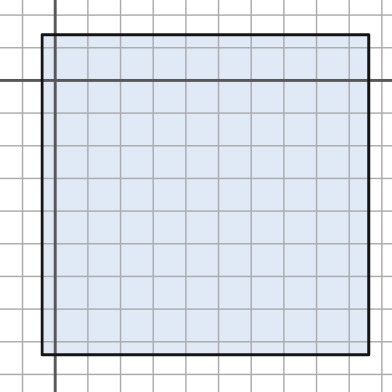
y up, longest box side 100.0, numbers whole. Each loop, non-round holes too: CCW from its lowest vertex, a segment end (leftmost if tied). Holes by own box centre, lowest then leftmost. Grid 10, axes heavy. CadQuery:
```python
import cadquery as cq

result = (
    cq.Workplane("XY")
    .moveTo(-4.0, -84.0)
    .lineTo(96.0, -84.0)
    .lineTo(96.0, 14.0)
    .lineTo(-4.0, 14.0)
    .close()
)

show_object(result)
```